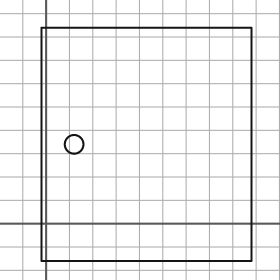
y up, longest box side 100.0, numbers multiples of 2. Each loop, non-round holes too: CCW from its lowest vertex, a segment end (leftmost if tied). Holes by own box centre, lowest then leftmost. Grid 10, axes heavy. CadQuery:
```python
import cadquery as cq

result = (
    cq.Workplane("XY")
    .moveTo(-2.0, -16.0)
    .lineTo(88.0, -16.0)
    .lineTo(88.0, 84.0)
    .lineTo(-2.0, 84.0)
    .close()
    .moveTo(12.0, 34.0)
    .circle(4.0)
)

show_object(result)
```